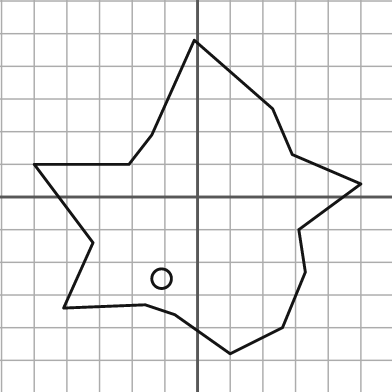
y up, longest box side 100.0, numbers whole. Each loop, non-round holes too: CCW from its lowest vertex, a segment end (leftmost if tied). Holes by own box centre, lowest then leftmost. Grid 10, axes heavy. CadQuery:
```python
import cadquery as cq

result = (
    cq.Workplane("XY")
    .moveTo(10.0, -48.0)
    .lineTo(26.0, -40.0)
    .lineTo(33.0, -23.0)
    .lineTo(31.0, -10.0)
    .lineTo(50.0, 4.0)
    .lineTo(29.0, 13.0)
    .lineTo(23.0, 27.0)
    .lineTo(-1.0, 48.0)
    .lineTo(-14.0, 19.0)
    .lineTo(-21.0, 10.0)
    .lineTo(-50.0, 10.0)
    .lineTo(-32.0, -14.0)
    .lineTo(-41.0, -34.0)
    .lineTo(-16.0, -33.0)
    .lineTo(-7.0, -36.0)
    .close()
    .moveTo(-11.0, -25.0)
    .circle(3.0)
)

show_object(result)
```